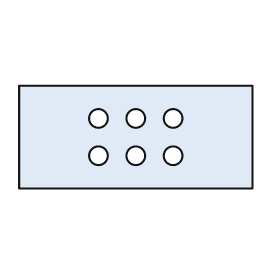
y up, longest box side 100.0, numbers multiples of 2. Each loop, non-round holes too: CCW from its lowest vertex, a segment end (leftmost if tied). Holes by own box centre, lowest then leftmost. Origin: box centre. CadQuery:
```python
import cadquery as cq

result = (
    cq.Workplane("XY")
    .moveTo(-50.0, -22.0)
    .lineTo(50.0, -22.0)
    .lineTo(50.0, 22.0)
    .lineTo(-50.0, 22.0)
    .close()
    .moveTo(-16.0, -8.0)
    .circle(4.0)
    .moveTo(0.0, -8.0)
    .circle(4.0)
    .moveTo(16.0, -8.0)
    .circle(4.0)
    .moveTo(-16.0, 8.0)
    .circle(4.0)
    .moveTo(0.0, 8.0)
    .circle(4.0)
    .moveTo(16.0, 8.0)
    .circle(4.0)
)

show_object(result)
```